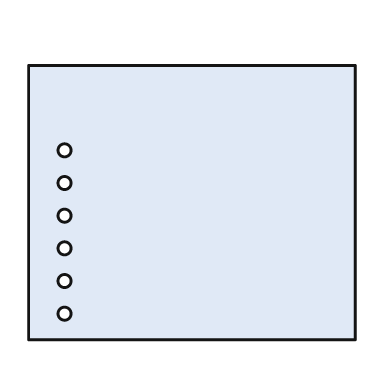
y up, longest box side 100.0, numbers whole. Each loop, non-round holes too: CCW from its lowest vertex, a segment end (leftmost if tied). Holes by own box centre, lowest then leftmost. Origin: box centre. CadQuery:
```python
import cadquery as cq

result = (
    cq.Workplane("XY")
    .moveTo(-50.0, -42.0)
    .lineTo(50.0, -42.0)
    .lineTo(50.0, 42.0)
    .lineTo(-50.0, 42.0)
    .close()
    .moveTo(-39.0, -34.0)
    .circle(2.0)
    .moveTo(-39.0, -24.0)
    .circle(2.0)
    .moveTo(-39.0, -14.0)
    .circle(2.0)
    .moveTo(-39.0, -4.0)
    .circle(2.0)
    .moveTo(-39.0, 6.0)
    .circle(2.0)
    .moveTo(-39.0, 16.0)
    .circle(2.0)
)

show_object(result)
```